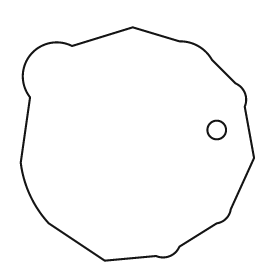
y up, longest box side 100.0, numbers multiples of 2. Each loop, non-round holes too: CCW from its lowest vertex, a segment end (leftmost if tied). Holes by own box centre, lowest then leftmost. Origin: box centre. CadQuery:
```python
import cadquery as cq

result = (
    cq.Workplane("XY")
    .moveTo(-14.0, -50.0)
    .lineTo(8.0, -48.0)
    .threePointArc((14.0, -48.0), (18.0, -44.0))
    .lineTo(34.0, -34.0)
    .threePointArc((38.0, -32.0), (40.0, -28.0))
    .lineTo(50.0, -6.0)
    .lineTo(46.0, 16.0)
    .threePointArc((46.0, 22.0), (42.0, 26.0))
    .lineTo(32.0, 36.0)
    .threePointArc((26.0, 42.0), (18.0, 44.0))
    .lineTo(-2.0, 50.0)
    .lineTo(-28.0, 42.0)
    .threePointArc((-46.0, 38.0), (-46.0, 20.0))
    .lineTo(-50.0, -8.0)
    .threePointArc((-46.0, -22.0), (-38.0, -34.0))
    .close()
    .moveTo(34.0, 6.0)
    .circle(4.0)
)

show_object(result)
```